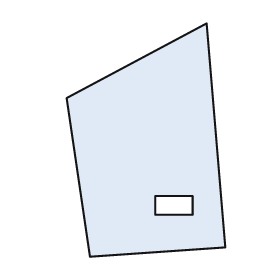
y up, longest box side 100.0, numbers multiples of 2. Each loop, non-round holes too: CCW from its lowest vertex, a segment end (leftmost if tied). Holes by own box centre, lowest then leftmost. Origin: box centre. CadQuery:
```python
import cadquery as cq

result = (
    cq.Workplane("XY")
    .moveTo(-24.0, -50.0)
    .lineTo(34.0, -46.0)
    .lineTo(26.0, 50.0)
    .lineTo(-34.0, 18.0)
    .close()
    .moveTo(4.0, -32.0)
    .lineTo(20.0, -32.0)
    .lineTo(20.0, -24.0)
    .lineTo(4.0, -24.0)
    .close()
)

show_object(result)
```